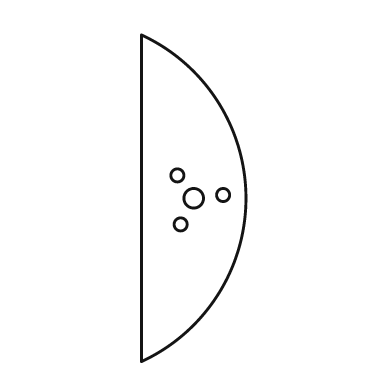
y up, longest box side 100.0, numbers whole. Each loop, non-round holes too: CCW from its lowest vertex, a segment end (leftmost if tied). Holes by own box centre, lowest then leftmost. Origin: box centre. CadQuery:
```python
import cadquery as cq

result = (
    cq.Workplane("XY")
    .moveTo(-16.0, -50.0)
    .threePointArc((16.0, 0.0), (-16.0, 50.0))
    .close()
    .moveTo(-4.0, -8.0)
    .circle(2.0)
    .moveTo(0.0, 0.0)
    .circle(3.0)
    .moveTo(9.0, 1.0)
    .circle(2.0)
    .moveTo(-5.0, 7.0)
    .circle(2.0)
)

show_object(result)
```